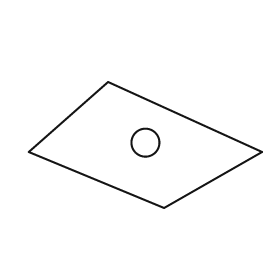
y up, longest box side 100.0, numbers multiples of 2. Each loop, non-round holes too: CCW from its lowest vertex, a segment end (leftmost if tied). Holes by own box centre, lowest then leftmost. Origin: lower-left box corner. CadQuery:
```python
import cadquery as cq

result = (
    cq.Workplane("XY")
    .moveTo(58.0, 0.0)
    .lineTo(100.0, 24.0)
    .lineTo(34.0, 54.0)
    .lineTo(0.0, 24.0)
    .close()
    .moveTo(50.0, 28.0)
    .circle(6.0)
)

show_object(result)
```